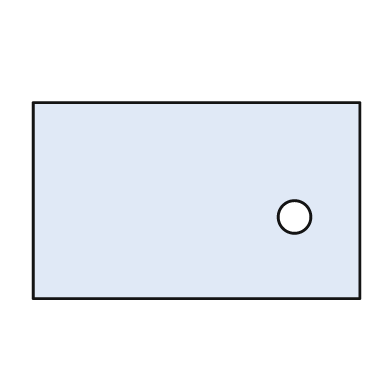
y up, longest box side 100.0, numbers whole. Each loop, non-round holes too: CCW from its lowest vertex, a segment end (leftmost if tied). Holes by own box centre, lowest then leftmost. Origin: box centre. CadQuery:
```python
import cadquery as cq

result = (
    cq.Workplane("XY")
    .moveTo(-50.0, -30.0)
    .lineTo(50.0, -30.0)
    .lineTo(50.0, 30.0)
    .lineTo(-50.0, 30.0)
    .close()
    .moveTo(30.0, -5.0)
    .circle(5.0)
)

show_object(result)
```